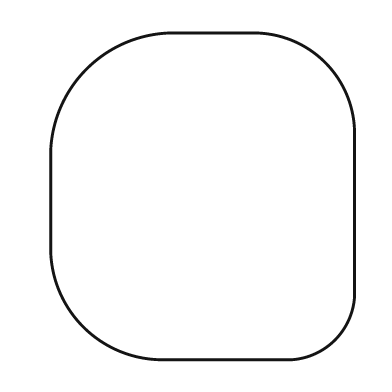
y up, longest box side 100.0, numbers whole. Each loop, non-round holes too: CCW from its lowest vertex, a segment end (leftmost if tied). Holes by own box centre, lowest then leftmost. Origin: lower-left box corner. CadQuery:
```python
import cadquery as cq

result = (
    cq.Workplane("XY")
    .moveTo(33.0, 0.0)
    .lineTo(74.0, 0.0)
    .threePointArc((87.0, 6.0), (93.0, 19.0))
    .lineTo(93.0, 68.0)
    .threePointArc((84.0, 91.0), (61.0, 100.0))
    .lineTo(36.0, 100.0)
    .threePointArc((11.0, 89.0), (0.0, 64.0))
    .lineTo(0.0, 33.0)
    .threePointArc((10.0, 10.0), (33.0, 0.0))
    .close()
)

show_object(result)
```